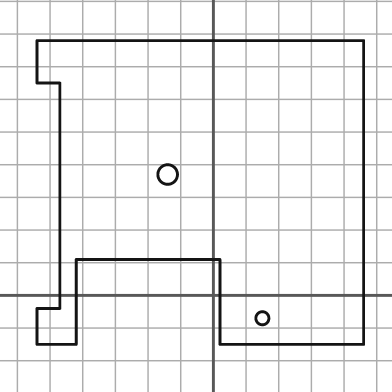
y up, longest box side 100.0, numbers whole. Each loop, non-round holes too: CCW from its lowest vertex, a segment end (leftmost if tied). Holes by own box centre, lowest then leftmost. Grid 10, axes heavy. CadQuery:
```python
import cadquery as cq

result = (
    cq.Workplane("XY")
    .moveTo(-54.0, -15.0)
    .lineTo(-42.0, -15.0)
    .lineTo(-42.0, 11.0)
    .lineTo(2.0, 11.0)
    .lineTo(2.0, -15.0)
    .lineTo(46.0, -15.0)
    .lineTo(46.0, 78.0)
    .lineTo(-54.0, 78.0)
    .lineTo(-54.0, 65.0)
    .lineTo(-47.0, 65.0)
    .lineTo(-47.0, -4.0)
    .lineTo(-54.0, -4.0)
    .close()
    .moveTo(15.0, -7.0)
    .circle(2.0)
    .moveTo(-14.0, 37.0)
    .circle(3.0)
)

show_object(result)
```